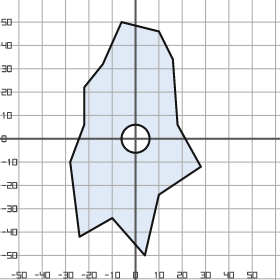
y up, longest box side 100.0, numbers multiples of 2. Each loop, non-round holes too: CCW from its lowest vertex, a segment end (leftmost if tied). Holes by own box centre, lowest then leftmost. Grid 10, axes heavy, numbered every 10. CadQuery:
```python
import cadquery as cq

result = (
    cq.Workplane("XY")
    .moveTo(4.0, -50.0)
    .lineTo(10.0, -24.0)
    .lineTo(28.0, -12.0)
    .lineTo(18.0, 6.0)
    .lineTo(16.0, 34.0)
    .lineTo(10.0, 46.0)
    .lineTo(-6.0, 50.0)
    .lineTo(-14.0, 32.0)
    .lineTo(-22.0, 22.0)
    .lineTo(-22.0, 6.0)
    .lineTo(-28.0, -10.0)
    .lineTo(-24.0, -42.0)
    .lineTo(-10.0, -34.0)
    .close()
    .moveTo(0.0, 0.0)
    .circle(6.0)
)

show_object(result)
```